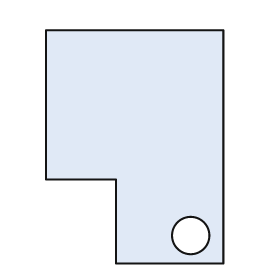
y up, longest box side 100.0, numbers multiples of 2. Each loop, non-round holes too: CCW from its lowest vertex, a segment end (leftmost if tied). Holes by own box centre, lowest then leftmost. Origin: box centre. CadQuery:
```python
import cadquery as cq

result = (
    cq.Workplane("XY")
    .moveTo(-8.0, -50.0)
    .lineTo(38.0, -50.0)
    .lineTo(38.0, 50.0)
    .lineTo(-38.0, 50.0)
    .lineTo(-38.0, -14.0)
    .lineTo(-8.0, -14.0)
    .close()
    .moveTo(24.0, -38.0)
    .circle(8.0)
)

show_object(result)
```